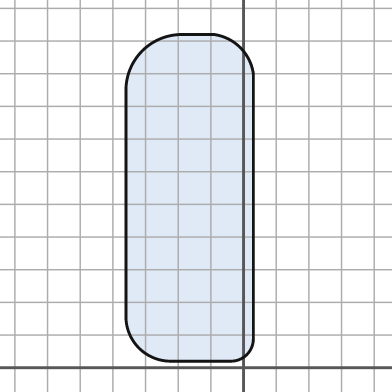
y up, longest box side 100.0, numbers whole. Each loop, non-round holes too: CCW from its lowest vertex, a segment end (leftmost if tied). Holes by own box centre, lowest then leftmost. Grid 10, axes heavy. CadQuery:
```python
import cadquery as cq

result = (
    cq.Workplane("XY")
    .moveTo(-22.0, 2.0)
    .lineTo(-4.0, 2.0)
    .threePointArc((1.0, 4.0), (3.0, 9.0))
    .lineTo(3.0, 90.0)
    .threePointArc((-1.0, 98.0), (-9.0, 102.0))
    .lineTo(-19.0, 102.0)
    .threePointArc((-31.0, 97.0), (-36.0, 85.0))
    .lineTo(-36.0, 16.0)
    .threePointArc((-32.0, 6.0), (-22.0, 2.0))
    .close()
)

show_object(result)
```